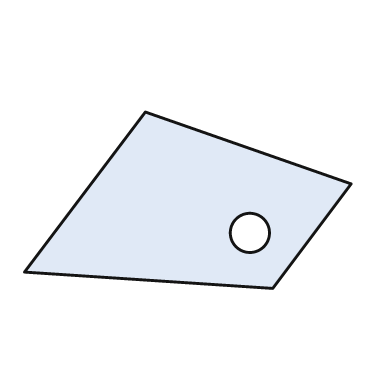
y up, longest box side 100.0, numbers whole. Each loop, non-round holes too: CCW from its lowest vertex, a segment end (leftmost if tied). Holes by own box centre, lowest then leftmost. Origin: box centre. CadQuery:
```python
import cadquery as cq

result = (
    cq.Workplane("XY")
    .moveTo(26.0, -27.0)
    .lineTo(50.0, 5.0)
    .lineTo(-13.0, 27.0)
    .lineTo(-50.0, -22.0)
    .close()
    .moveTo(19.0, -10.0)
    .circle(6.0)
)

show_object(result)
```